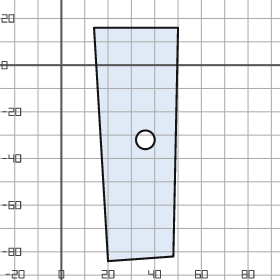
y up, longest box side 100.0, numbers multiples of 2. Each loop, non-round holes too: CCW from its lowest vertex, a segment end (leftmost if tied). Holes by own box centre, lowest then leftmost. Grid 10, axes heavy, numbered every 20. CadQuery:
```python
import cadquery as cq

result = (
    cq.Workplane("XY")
    .moveTo(20.0, -84.0)
    .lineTo(48.0, -82.0)
    .lineTo(50.0, 16.0)
    .lineTo(14.0, 16.0)
    .close()
    .moveTo(36.0, -32.0)
    .circle(4.0)
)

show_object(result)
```